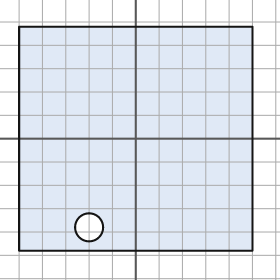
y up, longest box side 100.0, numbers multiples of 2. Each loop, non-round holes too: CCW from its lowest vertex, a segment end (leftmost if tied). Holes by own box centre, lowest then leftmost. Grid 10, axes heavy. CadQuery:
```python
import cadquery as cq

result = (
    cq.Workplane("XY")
    .moveTo(-50.0, -48.0)
    .lineTo(50.0, -48.0)
    .lineTo(50.0, 48.0)
    .lineTo(-50.0, 48.0)
    .close()
    .moveTo(-20.0, -38.0)
    .circle(6.0)
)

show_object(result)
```